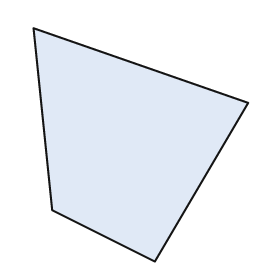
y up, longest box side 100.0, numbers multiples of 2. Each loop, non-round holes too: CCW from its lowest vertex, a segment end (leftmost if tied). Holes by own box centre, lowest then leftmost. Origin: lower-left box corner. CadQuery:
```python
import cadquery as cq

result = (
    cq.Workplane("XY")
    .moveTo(52.0, 0.0)
    .lineTo(92.0, 68.0)
    .lineTo(0.0, 100.0)
    .lineTo(8.0, 22.0)
    .close()
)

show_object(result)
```